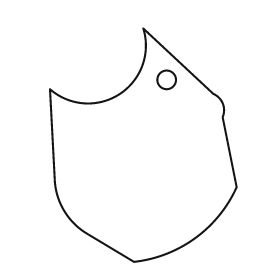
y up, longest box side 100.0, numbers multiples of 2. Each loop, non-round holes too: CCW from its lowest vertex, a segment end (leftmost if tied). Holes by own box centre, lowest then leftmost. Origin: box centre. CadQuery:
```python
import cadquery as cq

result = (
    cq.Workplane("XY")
    .moveTo(-4.0, -50.0)
    .threePointArc((22.0, -40.0), (40.0, -18.0))
    .lineTo(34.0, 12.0)
    .threePointArc((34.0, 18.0), (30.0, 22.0))
    .lineTo(0.0, 50.0)
    .threePointArc((-10.0, 22.0), (-40.0, 24.0))
    .lineTo(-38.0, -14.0)
    .threePointArc((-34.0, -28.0), (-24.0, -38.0))
    .close()
    .moveTo(10.0, 28.0)
    .circle(4.0)
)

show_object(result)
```